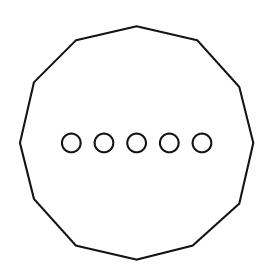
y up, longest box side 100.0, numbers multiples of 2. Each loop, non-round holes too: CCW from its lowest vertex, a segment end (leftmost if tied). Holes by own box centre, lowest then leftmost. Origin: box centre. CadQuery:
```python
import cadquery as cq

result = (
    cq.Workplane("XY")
    .moveTo(0.0, -50.0)
    .lineTo(24.0, -44.0)
    .lineTo(44.0, -26.0)
    .lineTo(50.0, 0.0)
    .lineTo(44.0, 24.0)
    .lineTo(26.0, 44.0)
    .lineTo(0.0, 50.0)
    .lineTo(-26.0, 44.0)
    .lineTo(-44.0, 26.0)
    .lineTo(-50.0, 0.0)
    .lineTo(-44.0, -24.0)
    .lineTo(-26.0, -44.0)
    .close()
    .moveTo(-28.0, 0.0)
    .circle(4.0)
    .moveTo(-14.0, 0.0)
    .circle(4.0)
    .moveTo(0.0, 0.0)
    .circle(4.0)
    .moveTo(14.0, 0.0)
    .circle(4.0)
    .moveTo(28.0, 0.0)
    .circle(4.0)
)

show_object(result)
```